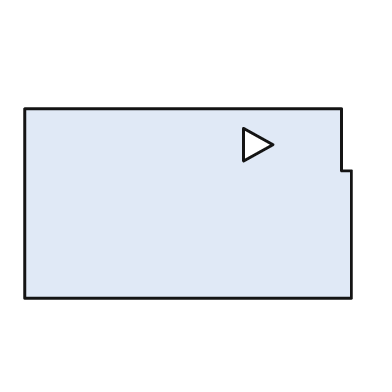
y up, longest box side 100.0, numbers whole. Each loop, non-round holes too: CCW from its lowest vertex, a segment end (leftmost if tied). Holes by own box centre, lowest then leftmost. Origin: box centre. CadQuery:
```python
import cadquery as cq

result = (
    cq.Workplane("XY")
    .moveTo(-50.0, -29.0)
    .lineTo(50.0, -29.0)
    .lineTo(50.0, 10.0)
    .lineTo(47.0, 10.0)
    .lineTo(47.0, 29.0)
    .lineTo(-50.0, 29.0)
    .close()
    .moveTo(17.0, 13.0)
    .lineTo(26.0, 18.0)
    .lineTo(17.0, 23.0)
    .close()
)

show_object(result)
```